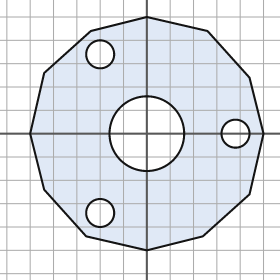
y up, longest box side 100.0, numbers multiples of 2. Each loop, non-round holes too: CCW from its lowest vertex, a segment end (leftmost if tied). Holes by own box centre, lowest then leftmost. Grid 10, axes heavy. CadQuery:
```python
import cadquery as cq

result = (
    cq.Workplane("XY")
    .moveTo(0.0, -50.0)
    .lineTo(24.0, -44.0)
    .lineTo(44.0, -26.0)
    .lineTo(50.0, 0.0)
    .lineTo(44.0, 24.0)
    .lineTo(26.0, 44.0)
    .lineTo(0.0, 50.0)
    .lineTo(-24.0, 44.0)
    .lineTo(-44.0, 26.0)
    .lineTo(-50.0, 0.0)
    .lineTo(-44.0, -24.0)
    .lineTo(-26.0, -44.0)
    .close()
    .moveTo(-20.0, -34.0)
    .circle(6.0)
    .moveTo(0.0, 0.0)
    .circle(16.0)
    .moveTo(38.0, 0.0)
    .circle(6.0)
    .moveTo(-20.0, 34.0)
    .circle(6.0)
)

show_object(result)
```